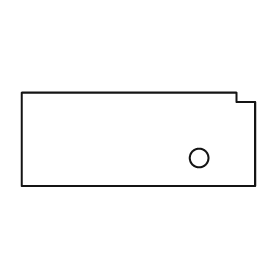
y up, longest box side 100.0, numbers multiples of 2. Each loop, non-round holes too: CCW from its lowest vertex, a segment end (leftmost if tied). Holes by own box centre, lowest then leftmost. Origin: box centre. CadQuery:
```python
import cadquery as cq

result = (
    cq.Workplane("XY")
    .moveTo(-50.0, -20.0)
    .lineTo(50.0, -20.0)
    .lineTo(50.0, 16.0)
    .lineTo(42.0, 16.0)
    .lineTo(42.0, 20.0)
    .lineTo(-50.0, 20.0)
    .close()
    .moveTo(26.0, -8.0)
    .circle(4.0)
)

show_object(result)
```